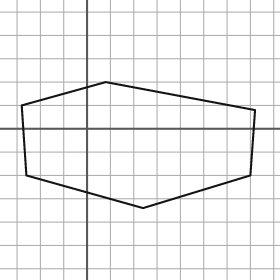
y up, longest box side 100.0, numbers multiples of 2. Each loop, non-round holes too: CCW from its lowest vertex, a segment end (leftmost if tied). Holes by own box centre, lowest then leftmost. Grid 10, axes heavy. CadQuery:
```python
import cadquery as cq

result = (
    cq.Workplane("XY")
    .moveTo(24.0, -34.0)
    .lineTo(70.0, -20.0)
    .lineTo(72.0, 8.0)
    .lineTo(8.0, 20.0)
    .lineTo(-28.0, 10.0)
    .lineTo(-26.0, -20.0)
    .close()
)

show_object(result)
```